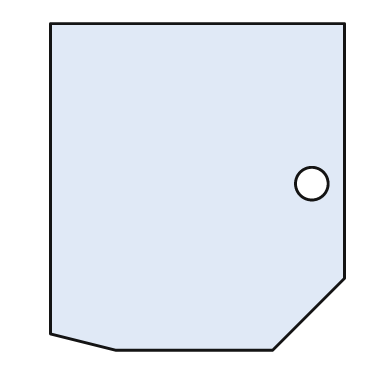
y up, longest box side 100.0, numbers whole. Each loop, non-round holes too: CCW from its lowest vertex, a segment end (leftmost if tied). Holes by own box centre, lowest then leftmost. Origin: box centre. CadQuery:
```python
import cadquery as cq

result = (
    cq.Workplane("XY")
    .moveTo(-25.0, -50.0)
    .lineTo(23.0, -50.0)
    .lineTo(45.0, -28.0)
    .lineTo(45.0, 50.0)
    .lineTo(-45.0, 50.0)
    .lineTo(-45.0, -45.0)
    .close()
    .moveTo(35.0, 1.0)
    .circle(5.0)
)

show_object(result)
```